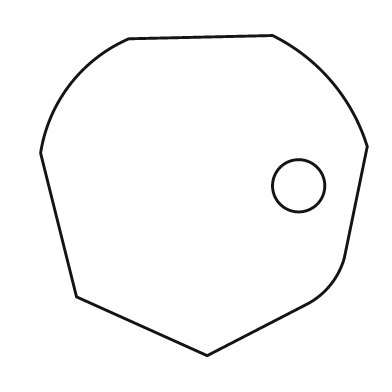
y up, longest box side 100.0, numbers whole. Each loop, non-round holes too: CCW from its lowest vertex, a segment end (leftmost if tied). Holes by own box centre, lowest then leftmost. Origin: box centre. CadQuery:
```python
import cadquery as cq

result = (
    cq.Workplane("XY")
    .moveTo(1.0, -49.0)
    .lineTo(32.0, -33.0)
    .threePointArc((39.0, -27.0), (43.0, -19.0))
    .lineTo(50.0, 15.0)
    .threePointArc((39.0, 35.0), (21.0, 49.0))
    .lineTo(-23.0, 48.0)
    .threePointArc((-41.0, 34.0), (-50.0, 13.0))
    .lineTo(-39.0, -31.0)
    .close()
    .moveTo(29.0, 3.0)
    .circle(8.0)
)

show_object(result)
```